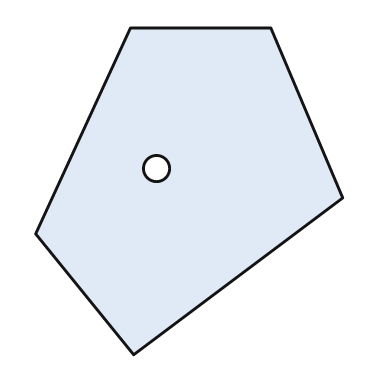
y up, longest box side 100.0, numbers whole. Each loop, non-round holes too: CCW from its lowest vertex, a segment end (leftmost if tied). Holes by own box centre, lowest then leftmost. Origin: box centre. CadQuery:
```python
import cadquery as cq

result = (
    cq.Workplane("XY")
    .moveTo(-17.0, -50.0)
    .lineTo(47.0, -2.0)
    .lineTo(25.0, 50.0)
    .lineTo(-18.0, 50.0)
    .lineTo(-47.0, -13.0)
    .close()
    .moveTo(-10.0, 7.0)
    .circle(4.0)
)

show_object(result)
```